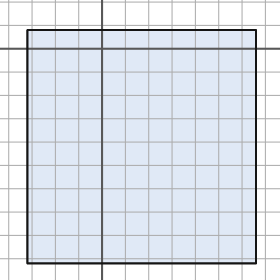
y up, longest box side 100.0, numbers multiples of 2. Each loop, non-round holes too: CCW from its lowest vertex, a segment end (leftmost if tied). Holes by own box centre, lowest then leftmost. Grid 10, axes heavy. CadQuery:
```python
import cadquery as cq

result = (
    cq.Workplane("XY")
    .moveTo(-32.0, -92.0)
    .lineTo(66.0, -92.0)
    .lineTo(66.0, 8.0)
    .lineTo(-32.0, 8.0)
    .close()
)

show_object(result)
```